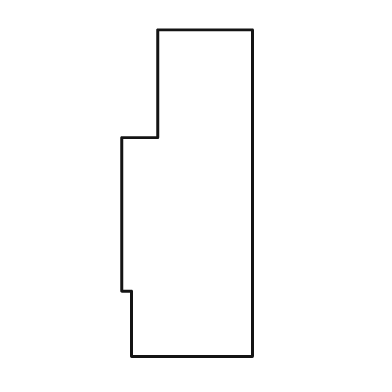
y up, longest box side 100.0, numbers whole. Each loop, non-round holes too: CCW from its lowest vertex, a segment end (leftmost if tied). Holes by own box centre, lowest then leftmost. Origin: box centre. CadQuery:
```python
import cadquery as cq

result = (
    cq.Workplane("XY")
    .moveTo(-17.0, -50.0)
    .lineTo(20.0, -50.0)
    .lineTo(20.0, 50.0)
    .lineTo(-9.0, 50.0)
    .lineTo(-9.0, 17.0)
    .lineTo(-20.0, 17.0)
    .lineTo(-20.0, -30.0)
    .lineTo(-17.0, -30.0)
    .close()
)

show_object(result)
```